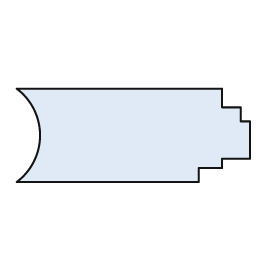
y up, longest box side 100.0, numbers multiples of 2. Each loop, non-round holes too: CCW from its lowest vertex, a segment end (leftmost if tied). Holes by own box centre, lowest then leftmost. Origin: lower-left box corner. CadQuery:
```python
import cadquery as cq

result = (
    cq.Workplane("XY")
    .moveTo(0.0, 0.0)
    .lineTo(78.0, 0.0)
    .lineTo(78.0, 6.0)
    .lineTo(88.0, 6.0)
    .lineTo(88.0, 10.0)
    .lineTo(100.0, 10.0)
    .lineTo(100.0, 26.0)
    .lineTo(96.0, 26.0)
    .lineTo(96.0, 32.0)
    .lineTo(88.0, 32.0)
    .lineTo(88.0, 40.0)
    .lineTo(0.0, 40.0)
    .threePointArc((10.0, 20.0), (0.0, 0.0))
    .close()
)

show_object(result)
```